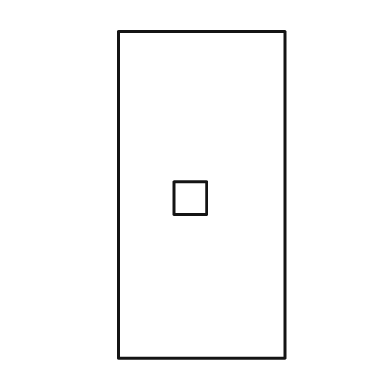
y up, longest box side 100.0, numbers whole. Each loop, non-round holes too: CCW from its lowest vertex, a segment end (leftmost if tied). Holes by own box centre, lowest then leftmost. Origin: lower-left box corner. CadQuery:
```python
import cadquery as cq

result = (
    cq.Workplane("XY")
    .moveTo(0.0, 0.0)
    .lineTo(51.0, 0.0)
    .lineTo(51.0, 100.0)
    .lineTo(0.0, 100.0)
    .close()
    .moveTo(17.0, 44.0)
    .lineTo(27.0, 44.0)
    .lineTo(27.0, 54.0)
    .lineTo(17.0, 54.0)
    .close()
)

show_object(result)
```